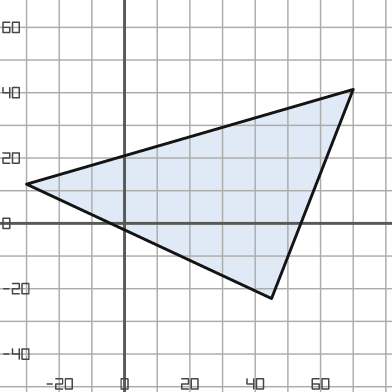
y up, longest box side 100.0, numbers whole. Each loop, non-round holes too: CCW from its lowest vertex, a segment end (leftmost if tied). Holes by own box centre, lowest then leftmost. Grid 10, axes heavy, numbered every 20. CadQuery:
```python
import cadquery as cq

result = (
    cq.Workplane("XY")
    .moveTo(45.0, -23.0)
    .lineTo(70.0, 41.0)
    .lineTo(-30.0, 12.0)
    .close()
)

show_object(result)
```